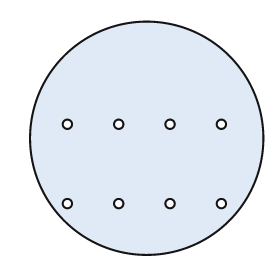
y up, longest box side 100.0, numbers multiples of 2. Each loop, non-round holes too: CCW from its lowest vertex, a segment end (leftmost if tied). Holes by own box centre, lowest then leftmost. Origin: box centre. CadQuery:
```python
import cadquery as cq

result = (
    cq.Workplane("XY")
    .moveTo(0.0, 0.0)
    .circle(50.0)
    .moveTo(-34.0, -28.0)
    .circle(2.0)
    .moveTo(-12.0, -28.0)
    .circle(2.0)
    .moveTo(10.0, -28.0)
    .circle(2.0)
    .moveTo(32.0, -28.0)
    .circle(2.0)
    .moveTo(-34.0, 6.0)
    .circle(2.0)
    .moveTo(-12.0, 6.0)
    .circle(2.0)
    .moveTo(10.0, 6.0)
    .circle(2.0)
    .moveTo(32.0, 6.0)
    .circle(2.0)
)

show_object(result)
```